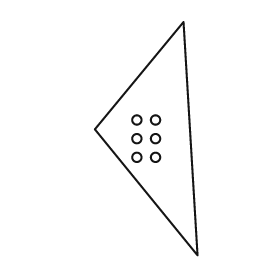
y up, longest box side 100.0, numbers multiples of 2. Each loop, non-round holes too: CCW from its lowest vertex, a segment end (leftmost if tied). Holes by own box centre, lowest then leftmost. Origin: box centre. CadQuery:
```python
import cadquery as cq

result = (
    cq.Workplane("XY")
    .moveTo(22.0, -50.0)
    .lineTo(16.0, 50.0)
    .lineTo(-22.0, 4.0)
    .close()
    .moveTo(-4.0, -8.0)
    .circle(2.0)
    .moveTo(4.0, -8.0)
    .circle(2.0)
    .moveTo(-4.0, 0.0)
    .circle(2.0)
    .moveTo(4.0, 0.0)
    .circle(2.0)
    .moveTo(-4.0, 8.0)
    .circle(2.0)
    .moveTo(4.0, 8.0)
    .circle(2.0)
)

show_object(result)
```